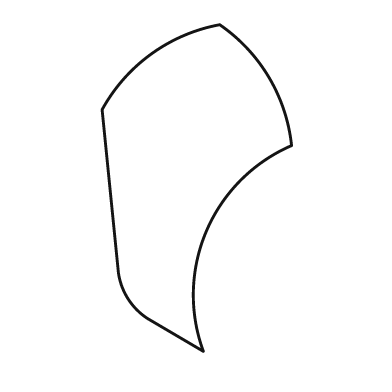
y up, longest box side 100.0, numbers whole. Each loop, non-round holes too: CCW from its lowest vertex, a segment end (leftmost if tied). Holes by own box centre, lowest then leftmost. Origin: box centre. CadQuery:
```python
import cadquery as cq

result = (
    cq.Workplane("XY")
    .moveTo(2.0, -50.0)
    .threePointArc((3.0, -13.0), (29.0, 13.0))
    .threePointArc((22.0, 34.0), (7.0, 50.0))
    .threePointArc((-14.0, 41.0), (-29.0, 24.0))
    .lineTo(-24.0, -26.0)
    .threePointArc((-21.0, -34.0), (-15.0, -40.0))
    .close()
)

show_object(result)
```